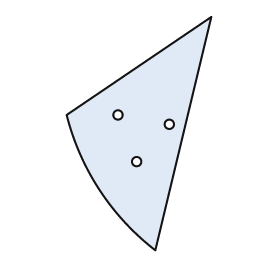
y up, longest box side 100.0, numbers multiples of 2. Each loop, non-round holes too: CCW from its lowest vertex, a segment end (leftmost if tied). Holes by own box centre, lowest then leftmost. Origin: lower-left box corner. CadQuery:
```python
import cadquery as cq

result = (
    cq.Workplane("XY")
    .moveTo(38.0, 0.0)
    .lineTo(62.0, 100.0)
    .lineTo(0.0, 58.0)
    .threePointArc((14.0, 26.0), (38.0, 0.0))
    .close()
    .moveTo(30.0, 38.0)
    .circle(2.0)
    .moveTo(44.0, 54.0)
    .circle(2.0)
    .moveTo(22.0, 58.0)
    .circle(2.0)
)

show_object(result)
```